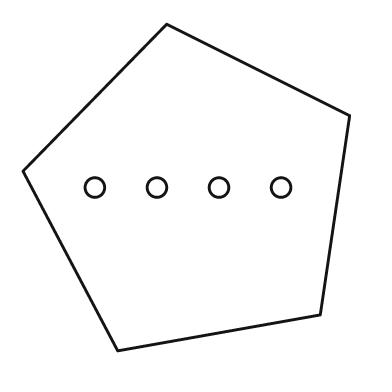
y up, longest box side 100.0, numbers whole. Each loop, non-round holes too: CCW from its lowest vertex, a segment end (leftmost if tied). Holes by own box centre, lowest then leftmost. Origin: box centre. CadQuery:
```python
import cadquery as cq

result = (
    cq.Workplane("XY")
    .moveTo(-21.0, -50.0)
    .lineTo(41.0, -39.0)
    .lineTo(50.0, 22.0)
    .lineTo(-6.0, 50.0)
    .lineTo(-50.0, 5.0)
    .close()
    .moveTo(-28.0, 0.0)
    .circle(3.0)
    .moveTo(-9.0, 0.0)
    .circle(3.0)
    .moveTo(10.0, 0.0)
    .circle(3.0)
    .moveTo(29.0, 0.0)
    .circle(3.0)
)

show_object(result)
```